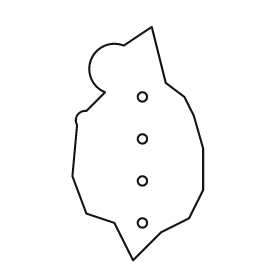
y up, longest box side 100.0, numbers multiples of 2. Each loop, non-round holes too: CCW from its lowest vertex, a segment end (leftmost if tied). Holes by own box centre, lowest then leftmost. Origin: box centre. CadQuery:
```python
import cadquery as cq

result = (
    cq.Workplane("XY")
    .moveTo(-2.0, -50.0)
    .lineTo(10.0, -38.0)
    .lineTo(22.0, -32.0)
    .lineTo(28.0, -20.0)
    .lineTo(28.0, -2.0)
    .lineTo(24.0, 12.0)
    .lineTo(20.0, 20.0)
    .lineTo(12.0, 26.0)
    .lineTo(6.0, 50.0)
    .lineTo(-6.0, 42.0)
    .threePointArc((-20.0, 36.0), (-14.0, 22.0))
    .lineTo(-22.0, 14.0)
    .threePointArc((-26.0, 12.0), (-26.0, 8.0))
    .lineTo(-28.0, -14.0)
    .lineTo(-22.0, -30.0)
    .lineTo(-10.0, -34.0)
    .close()
    .moveTo(2.0, -34.0)
    .circle(2.0)
    .moveTo(2.0, -16.0)
    .circle(2.0)
    .moveTo(2.0, 2.0)
    .circle(2.0)
    .moveTo(2.0, 20.0)
    .circle(2.0)
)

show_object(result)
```